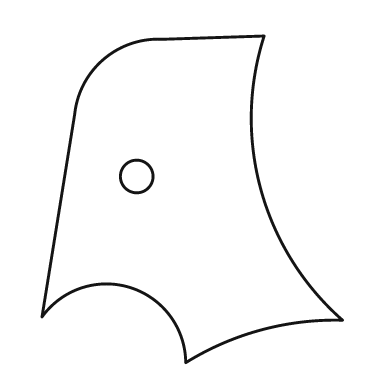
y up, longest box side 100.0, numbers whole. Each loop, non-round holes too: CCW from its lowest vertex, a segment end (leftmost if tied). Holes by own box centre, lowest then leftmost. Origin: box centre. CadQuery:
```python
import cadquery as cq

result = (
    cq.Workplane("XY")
    .moveTo(-2.0, -50.0)
    .threePointArc((21.0, -40.0), (46.0, -37.0))
    .threePointArc((21.0, 3.0), (22.0, 50.0))
    .lineTo(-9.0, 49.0)
    .threePointArc((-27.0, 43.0), (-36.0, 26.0))
    .lineTo(-46.0, -36.0)
    .threePointArc((-19.0, -27.0), (-2.0, -50.0))
    .close()
    .moveTo(-17.0, 7.0)
    .circle(5.0)
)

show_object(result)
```